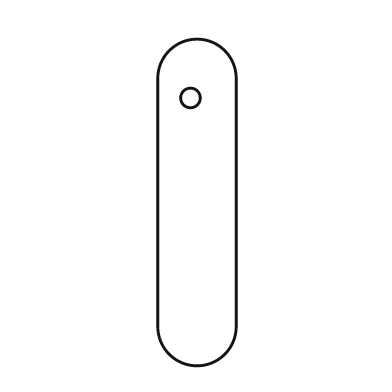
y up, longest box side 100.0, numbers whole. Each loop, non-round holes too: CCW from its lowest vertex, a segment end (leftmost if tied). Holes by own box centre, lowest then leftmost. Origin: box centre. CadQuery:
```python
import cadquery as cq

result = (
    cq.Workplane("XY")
    .moveTo(-12.0, -38.0)
    .threePointArc((0.0, -50.0), (12.0, -38.0))
    .lineTo(12.0, 38.0)
    .threePointArc((0.0, 50.0), (-12.0, 38.0))
    .close()
    .moveTo(-2.0, 32.0)
    .circle(3.0)
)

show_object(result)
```